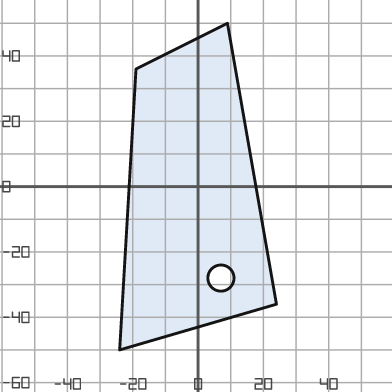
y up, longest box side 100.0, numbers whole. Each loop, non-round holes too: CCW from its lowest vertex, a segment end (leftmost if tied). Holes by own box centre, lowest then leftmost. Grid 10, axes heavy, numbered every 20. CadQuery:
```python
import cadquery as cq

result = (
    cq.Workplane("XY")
    .moveTo(-24.0, -50.0)
    .lineTo(24.0, -36.0)
    .lineTo(9.0, 50.0)
    .lineTo(-19.0, 36.0)
    .close()
    .moveTo(7.0, -28.0)
    .circle(4.0)
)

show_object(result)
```